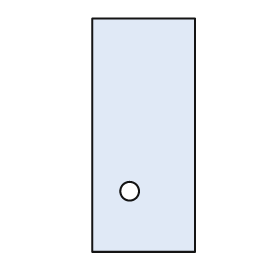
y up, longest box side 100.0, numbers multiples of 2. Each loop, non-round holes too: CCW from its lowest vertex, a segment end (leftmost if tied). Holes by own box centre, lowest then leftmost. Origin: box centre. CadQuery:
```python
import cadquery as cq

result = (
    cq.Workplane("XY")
    .moveTo(-22.0, -50.0)
    .lineTo(22.0, -50.0)
    .lineTo(22.0, 50.0)
    .lineTo(-22.0, 50.0)
    .close()
    .moveTo(-6.0, -24.0)
    .circle(4.0)
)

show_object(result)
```